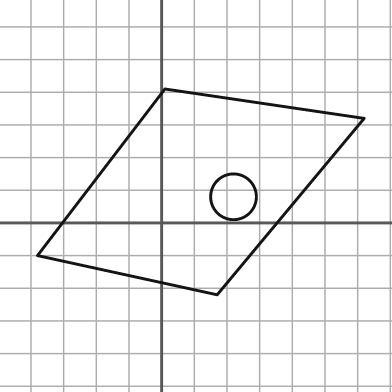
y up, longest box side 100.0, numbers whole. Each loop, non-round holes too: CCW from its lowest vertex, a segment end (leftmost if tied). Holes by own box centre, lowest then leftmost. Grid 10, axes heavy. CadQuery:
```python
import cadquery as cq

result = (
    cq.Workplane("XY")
    .moveTo(17.0, -22.0)
    .lineTo(62.0, 32.0)
    .lineTo(1.0, 41.0)
    .lineTo(-38.0, -10.0)
    .close()
    .moveTo(22.0, 8.0)
    .circle(7.0)
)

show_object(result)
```